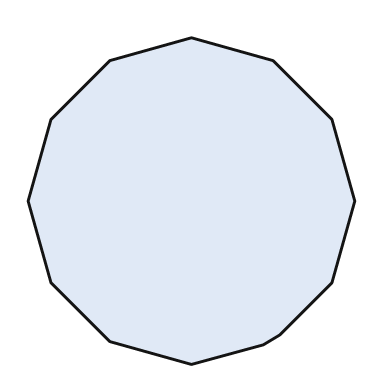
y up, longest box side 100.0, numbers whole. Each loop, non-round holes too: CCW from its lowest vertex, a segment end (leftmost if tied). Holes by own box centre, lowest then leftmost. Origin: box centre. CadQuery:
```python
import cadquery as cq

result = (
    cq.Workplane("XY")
    .moveTo(0.0, -50.0)
    .lineTo(22.0, -44.0)
    .lineTo(27.0, -41.0)
    .lineTo(43.0, -25.0)
    .lineTo(50.0, 0.0)
    .lineTo(43.0, 25.0)
    .lineTo(25.0, 43.0)
    .lineTo(0.0, 50.0)
    .lineTo(-25.0, 43.0)
    .lineTo(-43.0, 25.0)
    .lineTo(-50.0, 0.0)
    .lineTo(-43.0, -25.0)
    .lineTo(-25.0, -43.0)
    .close()
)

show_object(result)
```